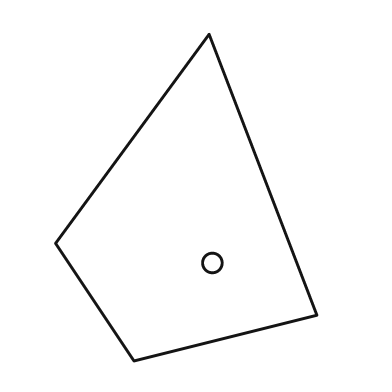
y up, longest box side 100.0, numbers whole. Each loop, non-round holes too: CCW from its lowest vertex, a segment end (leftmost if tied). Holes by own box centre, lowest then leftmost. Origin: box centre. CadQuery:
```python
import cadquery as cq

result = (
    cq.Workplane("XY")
    .moveTo(-16.0, -50.0)
    .lineTo(40.0, -36.0)
    .lineTo(7.0, 50.0)
    .lineTo(-40.0, -14.0)
    .close()
    .moveTo(8.0, -20.0)
    .circle(3.0)
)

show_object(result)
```